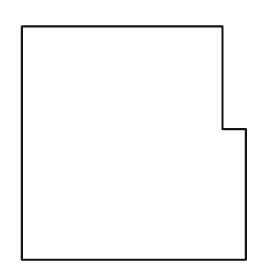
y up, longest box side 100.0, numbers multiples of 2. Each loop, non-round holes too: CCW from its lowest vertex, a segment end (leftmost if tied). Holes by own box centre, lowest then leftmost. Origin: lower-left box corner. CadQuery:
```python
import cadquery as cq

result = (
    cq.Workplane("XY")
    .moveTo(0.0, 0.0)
    .lineTo(96.0, 0.0)
    .lineTo(96.0, 56.0)
    .lineTo(86.0, 56.0)
    .lineTo(86.0, 100.0)
    .lineTo(0.0, 100.0)
    .close()
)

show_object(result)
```